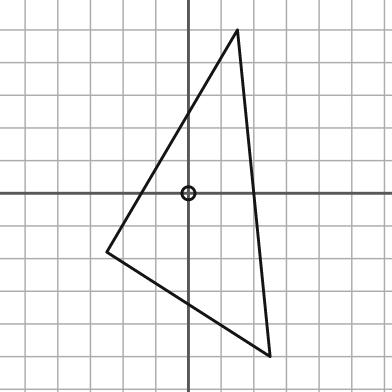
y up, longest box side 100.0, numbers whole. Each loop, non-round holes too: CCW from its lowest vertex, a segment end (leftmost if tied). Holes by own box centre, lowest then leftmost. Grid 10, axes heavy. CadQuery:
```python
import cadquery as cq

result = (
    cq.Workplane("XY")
    .moveTo(25.0, -50.0)
    .lineTo(15.0, 50.0)
    .lineTo(-25.0, -18.0)
    .close()
    .moveTo(0.0, 0.0)
    .circle(2.0)
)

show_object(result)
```